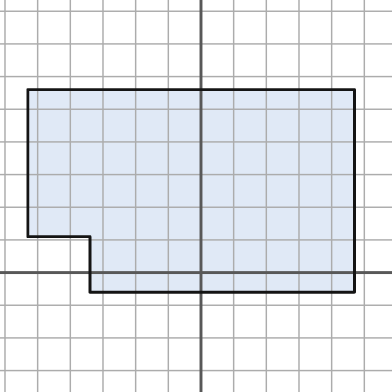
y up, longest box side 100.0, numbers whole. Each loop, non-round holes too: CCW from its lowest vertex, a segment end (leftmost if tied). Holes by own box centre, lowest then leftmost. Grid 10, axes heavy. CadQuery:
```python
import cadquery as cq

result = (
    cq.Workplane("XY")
    .moveTo(-34.0, -6.0)
    .lineTo(47.0, -6.0)
    .lineTo(47.0, 56.0)
    .lineTo(-53.0, 56.0)
    .lineTo(-53.0, 11.0)
    .lineTo(-34.0, 11.0)
    .close()
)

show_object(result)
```